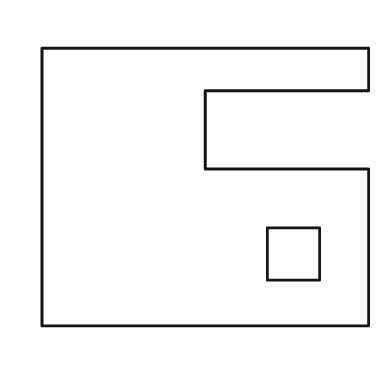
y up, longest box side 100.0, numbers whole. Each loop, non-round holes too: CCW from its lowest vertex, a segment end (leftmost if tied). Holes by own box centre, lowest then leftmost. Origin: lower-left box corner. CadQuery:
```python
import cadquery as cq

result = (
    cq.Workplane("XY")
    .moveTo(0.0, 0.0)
    .lineTo(100.0, 0.0)
    .lineTo(100.0, 48.0)
    .lineTo(50.0, 48.0)
    .lineTo(50.0, 72.0)
    .lineTo(100.0, 72.0)
    .lineTo(100.0, 85.0)
    .lineTo(0.0, 85.0)
    .close()
    .moveTo(69.0, 14.0)
    .lineTo(85.0, 14.0)
    .lineTo(85.0, 30.0)
    .lineTo(69.0, 30.0)
    .close()
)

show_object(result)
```